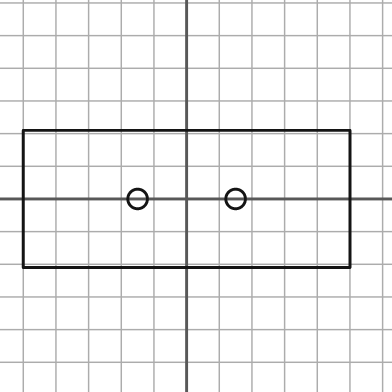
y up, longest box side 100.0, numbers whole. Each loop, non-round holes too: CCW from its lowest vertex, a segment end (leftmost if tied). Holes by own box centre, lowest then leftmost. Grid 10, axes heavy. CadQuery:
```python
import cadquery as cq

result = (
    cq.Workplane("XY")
    .moveTo(-50.0, -21.0)
    .lineTo(50.0, -21.0)
    .lineTo(50.0, 21.0)
    .lineTo(-50.0, 21.0)
    .close()
    .moveTo(-15.0, 0.0)
    .circle(3.0)
    .moveTo(15.0, 0.0)
    .circle(3.0)
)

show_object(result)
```